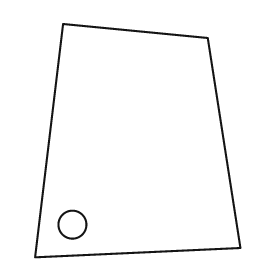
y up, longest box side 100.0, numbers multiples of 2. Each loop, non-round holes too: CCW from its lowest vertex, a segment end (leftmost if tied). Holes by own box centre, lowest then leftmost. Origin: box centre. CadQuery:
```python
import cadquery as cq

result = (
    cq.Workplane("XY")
    .moveTo(-44.0, -50.0)
    .lineTo(44.0, -46.0)
    .lineTo(30.0, 44.0)
    .lineTo(-32.0, 50.0)
    .close()
    .moveTo(-28.0, -36.0)
    .circle(6.0)
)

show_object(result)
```